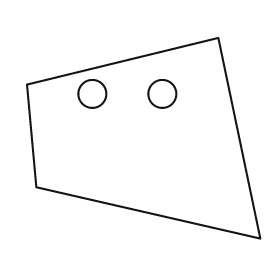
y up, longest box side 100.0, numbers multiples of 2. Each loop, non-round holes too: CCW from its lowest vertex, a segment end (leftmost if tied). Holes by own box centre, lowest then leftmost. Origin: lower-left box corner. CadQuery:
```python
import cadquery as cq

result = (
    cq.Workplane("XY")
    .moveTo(100.0, 0.0)
    .lineTo(82.0, 86.0)
    .lineTo(0.0, 66.0)
    .lineTo(4.0, 22.0)
    .close()
    .moveTo(28.0, 62.0)
    .circle(6.0)
    .moveTo(58.0, 62.0)
    .circle(6.0)
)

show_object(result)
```